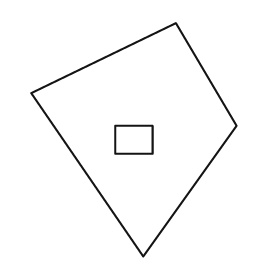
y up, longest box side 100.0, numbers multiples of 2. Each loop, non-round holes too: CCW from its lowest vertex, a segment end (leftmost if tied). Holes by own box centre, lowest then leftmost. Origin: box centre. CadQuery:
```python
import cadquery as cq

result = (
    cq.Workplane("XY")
    .moveTo(4.0, -50.0)
    .lineTo(44.0, 6.0)
    .lineTo(18.0, 50.0)
    .lineTo(-44.0, 20.0)
    .close()
    .moveTo(-8.0, -6.0)
    .lineTo(8.0, -6.0)
    .lineTo(8.0, 6.0)
    .lineTo(-8.0, 6.0)
    .close()
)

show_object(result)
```